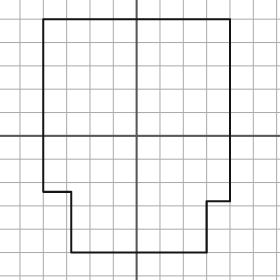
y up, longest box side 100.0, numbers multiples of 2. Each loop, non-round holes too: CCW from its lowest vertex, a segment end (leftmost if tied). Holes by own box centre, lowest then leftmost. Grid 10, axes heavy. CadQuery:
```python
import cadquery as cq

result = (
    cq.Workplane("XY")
    .moveTo(-28.0, -50.0)
    .lineTo(30.0, -50.0)
    .lineTo(30.0, -28.0)
    .lineTo(40.0, -28.0)
    .lineTo(40.0, 50.0)
    .lineTo(-40.0, 50.0)
    .lineTo(-40.0, -24.0)
    .lineTo(-28.0, -24.0)
    .close()
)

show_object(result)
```